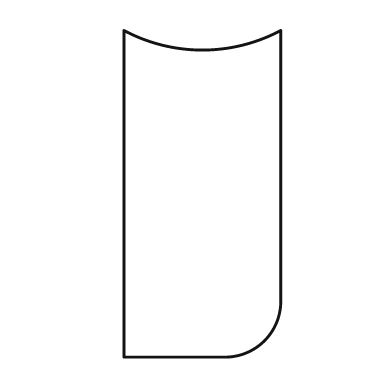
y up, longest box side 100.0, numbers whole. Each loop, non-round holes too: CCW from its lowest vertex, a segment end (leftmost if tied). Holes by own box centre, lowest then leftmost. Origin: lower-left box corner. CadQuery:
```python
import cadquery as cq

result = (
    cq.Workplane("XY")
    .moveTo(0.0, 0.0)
    .lineTo(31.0, 0.0)
    .threePointArc((43.0, 5.0), (48.0, 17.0))
    .lineTo(48.0, 100.0)
    .threePointArc((24.0, 94.0), (0.0, 100.0))
    .close()
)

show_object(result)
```